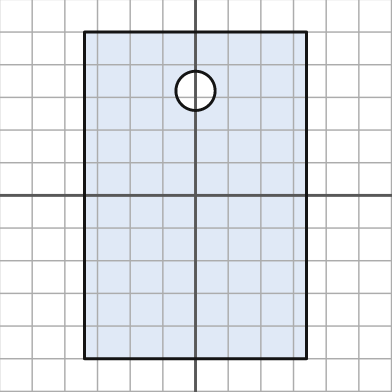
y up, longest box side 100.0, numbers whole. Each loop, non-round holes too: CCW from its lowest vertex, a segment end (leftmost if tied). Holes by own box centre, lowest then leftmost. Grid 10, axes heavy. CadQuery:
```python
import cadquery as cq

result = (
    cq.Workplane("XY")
    .moveTo(-34.0, -50.0)
    .lineTo(34.0, -50.0)
    .lineTo(34.0, 50.0)
    .lineTo(-34.0, 50.0)
    .close()
    .moveTo(0.0, 32.0)
    .circle(6.0)
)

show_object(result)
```